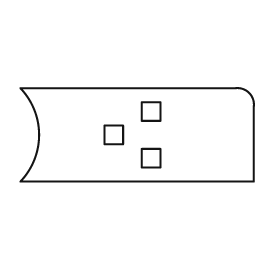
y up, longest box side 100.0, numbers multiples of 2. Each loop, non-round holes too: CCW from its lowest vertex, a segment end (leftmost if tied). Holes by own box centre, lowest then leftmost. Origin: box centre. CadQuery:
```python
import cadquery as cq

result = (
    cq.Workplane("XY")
    .moveTo(-50.0, -20.0)
    .lineTo(50.0, -20.0)
    .lineTo(50.0, 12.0)
    .threePointArc((48.0, 18.0), (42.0, 20.0))
    .lineTo(-50.0, 20.0)
    .threePointArc((-42.0, 0.0), (-50.0, -20.0))
    .close()
    .moveTo(2.0, -14.0)
    .lineTo(10.0, -14.0)
    .lineTo(10.0, -6.0)
    .lineTo(2.0, -6.0)
    .close()
    .moveTo(-14.0, -4.0)
    .lineTo(-6.0, -4.0)
    .lineTo(-6.0, 4.0)
    .lineTo(-14.0, 4.0)
    .close()
    .moveTo(2.0, 6.0)
    .lineTo(10.0, 6.0)
    .lineTo(10.0, 14.0)
    .lineTo(2.0, 14.0)
    .close()
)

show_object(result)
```